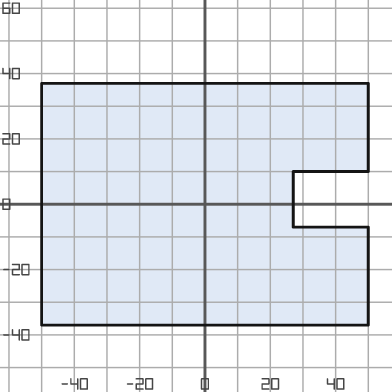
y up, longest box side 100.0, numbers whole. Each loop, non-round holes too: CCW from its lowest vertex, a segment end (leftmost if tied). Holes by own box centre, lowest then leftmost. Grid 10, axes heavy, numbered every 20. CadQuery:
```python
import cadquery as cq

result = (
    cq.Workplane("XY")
    .moveTo(-50.0, -37.0)
    .lineTo(50.0, -37.0)
    .lineTo(50.0, -7.0)
    .lineTo(27.0, -7.0)
    .lineTo(27.0, 10.0)
    .lineTo(50.0, 10.0)
    .lineTo(50.0, 37.0)
    .lineTo(-50.0, 37.0)
    .close()
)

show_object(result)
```